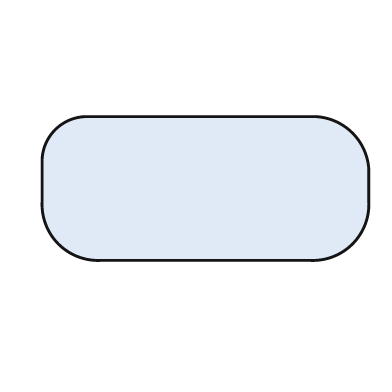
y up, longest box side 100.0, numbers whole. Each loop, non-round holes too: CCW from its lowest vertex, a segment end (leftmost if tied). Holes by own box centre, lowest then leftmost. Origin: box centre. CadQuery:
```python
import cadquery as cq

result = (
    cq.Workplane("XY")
    .moveTo(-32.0, -22.0)
    .lineTo(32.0, -22.0)
    .threePointArc((45.0, -17.0), (50.0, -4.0))
    .lineTo(50.0, 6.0)
    .threePointArc((45.0, 17.0), (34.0, 22.0))
    .lineTo(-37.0, 22.0)
    .threePointArc((-46.0, 18.0), (-50.0, 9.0))
    .lineTo(-50.0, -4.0)
    .threePointArc((-45.0, -17.0), (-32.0, -22.0))
    .close()
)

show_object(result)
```